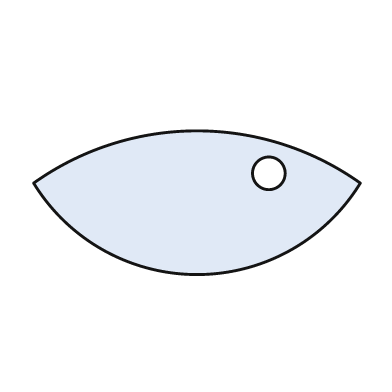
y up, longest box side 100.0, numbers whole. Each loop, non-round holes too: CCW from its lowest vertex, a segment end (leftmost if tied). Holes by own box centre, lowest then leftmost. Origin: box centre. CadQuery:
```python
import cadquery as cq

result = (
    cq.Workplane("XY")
    .moveTo(-50.0, 6.0)
    .threePointArc((0.0, -22.0), (50.0, 6.0))
    .threePointArc((0.0, 22.0), (-50.0, 6.0))
    .close()
    .moveTo(22.0, 9.0)
    .circle(5.0)
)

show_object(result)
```